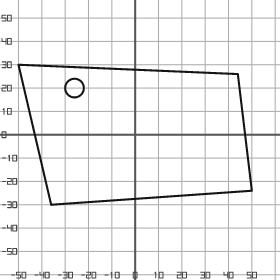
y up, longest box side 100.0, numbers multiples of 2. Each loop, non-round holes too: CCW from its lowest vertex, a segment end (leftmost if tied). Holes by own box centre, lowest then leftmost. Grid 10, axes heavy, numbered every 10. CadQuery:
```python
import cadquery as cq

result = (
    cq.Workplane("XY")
    .moveTo(-36.0, -30.0)
    .lineTo(50.0, -24.0)
    .lineTo(44.0, 26.0)
    .lineTo(-50.0, 30.0)
    .close()
    .moveTo(-26.0, 20.0)
    .circle(4.0)
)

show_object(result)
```